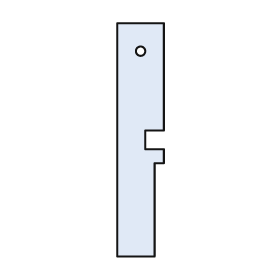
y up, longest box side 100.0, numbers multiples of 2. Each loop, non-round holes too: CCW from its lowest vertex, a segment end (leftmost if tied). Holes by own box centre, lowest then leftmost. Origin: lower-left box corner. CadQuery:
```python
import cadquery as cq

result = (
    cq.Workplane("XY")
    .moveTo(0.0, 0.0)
    .lineTo(16.0, 0.0)
    .lineTo(16.0, 40.0)
    .lineTo(20.0, 40.0)
    .lineTo(20.0, 46.0)
    .lineTo(12.0, 46.0)
    .lineTo(12.0, 54.0)
    .lineTo(20.0, 54.0)
    .lineTo(20.0, 100.0)
    .lineTo(0.0, 100.0)
    .close()
    .moveTo(10.0, 88.0)
    .circle(2.0)
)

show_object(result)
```